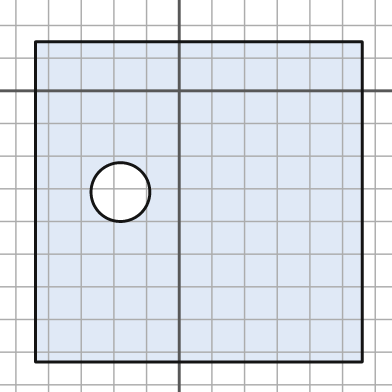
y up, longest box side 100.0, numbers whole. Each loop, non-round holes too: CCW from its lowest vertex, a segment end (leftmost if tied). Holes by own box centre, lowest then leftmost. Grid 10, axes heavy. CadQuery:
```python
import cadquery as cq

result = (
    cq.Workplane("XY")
    .moveTo(-44.0, -83.0)
    .lineTo(56.0, -83.0)
    .lineTo(56.0, 15.0)
    .lineTo(-44.0, 15.0)
    .close()
    .moveTo(-18.0, -31.0)
    .circle(9.0)
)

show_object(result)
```